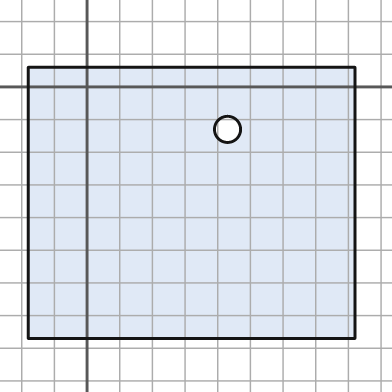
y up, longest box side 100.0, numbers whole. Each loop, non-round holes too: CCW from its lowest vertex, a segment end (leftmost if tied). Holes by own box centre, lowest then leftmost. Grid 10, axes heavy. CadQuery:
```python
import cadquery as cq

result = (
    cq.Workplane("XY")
    .moveTo(-18.0, -77.0)
    .lineTo(82.0, -77.0)
    .lineTo(82.0, 6.0)
    .lineTo(-18.0, 6.0)
    .close()
    .moveTo(43.0, -13.0)
    .circle(4.0)
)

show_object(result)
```